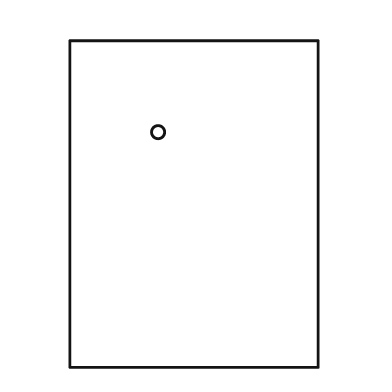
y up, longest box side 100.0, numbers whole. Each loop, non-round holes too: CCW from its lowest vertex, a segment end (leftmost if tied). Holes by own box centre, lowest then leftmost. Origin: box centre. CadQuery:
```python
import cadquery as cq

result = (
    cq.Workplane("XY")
    .moveTo(-38.0, -50.0)
    .lineTo(38.0, -50.0)
    .lineTo(38.0, 50.0)
    .lineTo(-38.0, 50.0)
    .close()
    .moveTo(-11.0, 22.0)
    .circle(2.0)
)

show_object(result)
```